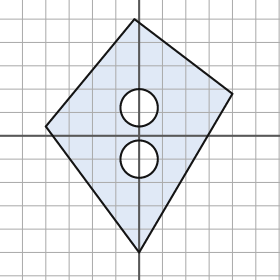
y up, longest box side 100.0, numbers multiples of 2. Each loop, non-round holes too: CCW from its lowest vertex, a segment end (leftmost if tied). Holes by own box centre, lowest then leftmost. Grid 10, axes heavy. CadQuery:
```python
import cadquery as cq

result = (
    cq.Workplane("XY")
    .moveTo(0.0, -50.0)
    .lineTo(40.0, 18.0)
    .lineTo(-2.0, 50.0)
    .lineTo(-40.0, 4.0)
    .close()
    .moveTo(0.0, -10.0)
    .circle(8.0)
    .moveTo(0.0, 12.0)
    .circle(8.0)
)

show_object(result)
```